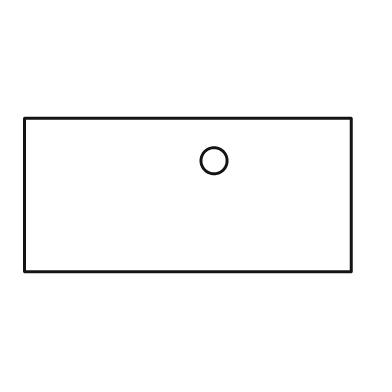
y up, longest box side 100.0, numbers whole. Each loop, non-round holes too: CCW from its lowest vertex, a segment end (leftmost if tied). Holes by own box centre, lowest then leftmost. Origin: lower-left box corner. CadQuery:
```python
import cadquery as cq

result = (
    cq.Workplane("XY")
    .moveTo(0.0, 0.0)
    .lineTo(100.0, 0.0)
    .lineTo(100.0, 47.0)
    .lineTo(0.0, 47.0)
    .close()
    .moveTo(58.0, 34.0)
    .circle(4.0)
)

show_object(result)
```